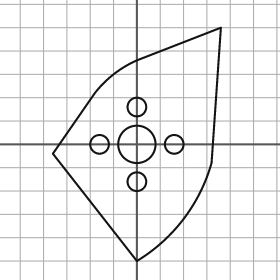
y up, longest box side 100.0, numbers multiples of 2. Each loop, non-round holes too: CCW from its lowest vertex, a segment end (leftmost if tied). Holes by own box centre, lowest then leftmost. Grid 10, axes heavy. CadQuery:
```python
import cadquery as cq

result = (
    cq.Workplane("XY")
    .moveTo(0.0, -50.0)
    .threePointArc((20.0, -32.0), (32.0, -8.0))
    .lineTo(36.0, 50.0)
    .lineTo(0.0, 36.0)
    .threePointArc((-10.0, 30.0), (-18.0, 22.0))
    .lineTo(-36.0, -4.0)
    .close()
    .moveTo(0.0, -16.0)
    .circle(4.0)
    .moveTo(-16.0, 0.0)
    .circle(4.0)
    .moveTo(0.0, 0.0)
    .circle(8.0)
    .moveTo(16.0, 0.0)
    .circle(4.0)
    .moveTo(0.0, 16.0)
    .circle(4.0)
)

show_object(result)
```